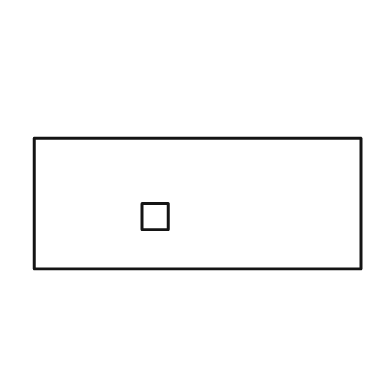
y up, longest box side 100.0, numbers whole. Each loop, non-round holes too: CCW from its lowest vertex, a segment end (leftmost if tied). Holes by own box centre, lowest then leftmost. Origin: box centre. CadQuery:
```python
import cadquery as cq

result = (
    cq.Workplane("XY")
    .moveTo(-50.0, -20.0)
    .lineTo(50.0, -20.0)
    .lineTo(50.0, 20.0)
    .lineTo(-50.0, 20.0)
    .close()
    .moveTo(-17.0, -8.0)
    .lineTo(-9.0, -8.0)
    .lineTo(-9.0, 0.0)
    .lineTo(-17.0, 0.0)
    .close()
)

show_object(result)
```